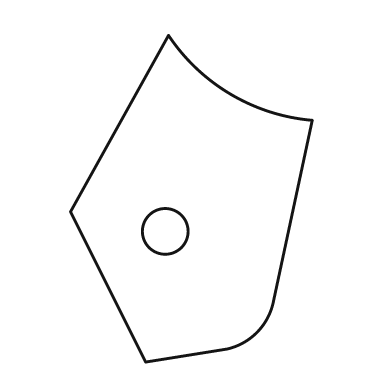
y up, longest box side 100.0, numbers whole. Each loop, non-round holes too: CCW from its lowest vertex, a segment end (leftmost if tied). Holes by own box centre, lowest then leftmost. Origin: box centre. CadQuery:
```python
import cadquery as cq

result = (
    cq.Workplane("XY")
    .moveTo(-14.0, -50.0)
    .lineTo(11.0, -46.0)
    .threePointArc((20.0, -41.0), (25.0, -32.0))
    .lineTo(37.0, 24.0)
    .threePointArc((12.0, 32.0), (-7.0, 50.0))
    .lineTo(-37.0, -4.0)
    .close()
    .moveTo(-8.0, -10.0)
    .circle(7.0)
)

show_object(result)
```